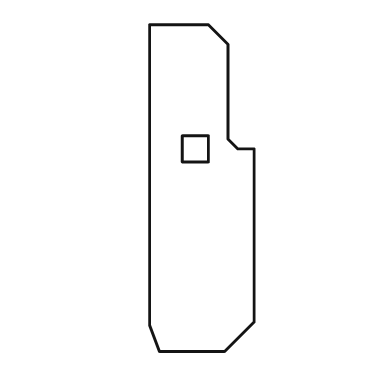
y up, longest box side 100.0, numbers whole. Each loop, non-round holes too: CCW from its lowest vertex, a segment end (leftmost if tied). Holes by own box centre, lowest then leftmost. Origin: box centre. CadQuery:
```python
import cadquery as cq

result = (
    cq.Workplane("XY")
    .moveTo(-13.0, -50.0)
    .lineTo(7.0, -50.0)
    .lineTo(16.0, -41.0)
    .lineTo(16.0, 12.0)
    .lineTo(11.0, 12.0)
    .lineTo(8.0, 15.0)
    .lineTo(8.0, 44.0)
    .lineTo(2.0, 50.0)
    .lineTo(-16.0, 50.0)
    .lineTo(-16.0, -42.0)
    .close()
    .moveTo(-6.0, 8.0)
    .lineTo(2.0, 8.0)
    .lineTo(2.0, 16.0)
    .lineTo(-6.0, 16.0)
    .close()
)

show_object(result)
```